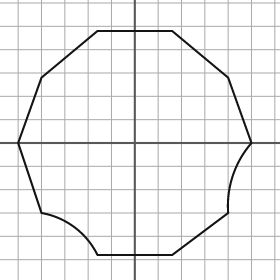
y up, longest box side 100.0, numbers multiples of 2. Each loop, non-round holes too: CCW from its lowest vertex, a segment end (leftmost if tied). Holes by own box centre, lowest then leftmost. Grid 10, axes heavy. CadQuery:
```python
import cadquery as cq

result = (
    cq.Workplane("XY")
    .moveTo(-16.0, -48.0)
    .lineTo(16.0, -48.0)
    .lineTo(40.0, -30.0)
    .threePointArc((42.0, -14.0), (50.0, 0.0))
    .lineTo(40.0, 28.0)
    .lineTo(16.0, 48.0)
    .lineTo(-16.0, 48.0)
    .lineTo(-40.0, 28.0)
    .lineTo(-50.0, 0.0)
    .lineTo(-40.0, -30.0)
    .threePointArc((-26.0, -36.0), (-16.0, -48.0))
    .close()
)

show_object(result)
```